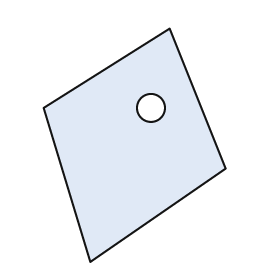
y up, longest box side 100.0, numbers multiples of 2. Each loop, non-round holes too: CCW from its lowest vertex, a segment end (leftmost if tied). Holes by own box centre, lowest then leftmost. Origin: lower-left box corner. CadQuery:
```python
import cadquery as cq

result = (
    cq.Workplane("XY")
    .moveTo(20.0, 0.0)
    .lineTo(78.0, 40.0)
    .lineTo(54.0, 100.0)
    .lineTo(0.0, 66.0)
    .close()
    .moveTo(46.0, 66.0)
    .circle(6.0)
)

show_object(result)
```